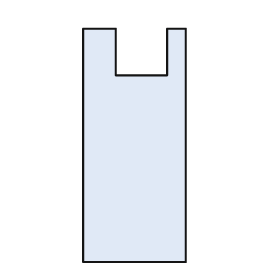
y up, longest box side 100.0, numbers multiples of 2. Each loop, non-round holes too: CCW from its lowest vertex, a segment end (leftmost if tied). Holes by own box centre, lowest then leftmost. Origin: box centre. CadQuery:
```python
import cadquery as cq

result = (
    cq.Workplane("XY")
    .moveTo(-22.0, -50.0)
    .lineTo(22.0, -50.0)
    .lineTo(22.0, 50.0)
    .lineTo(14.0, 50.0)
    .lineTo(14.0, 30.0)
    .lineTo(-8.0, 30.0)
    .lineTo(-8.0, 50.0)
    .lineTo(-22.0, 50.0)
    .close()
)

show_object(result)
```